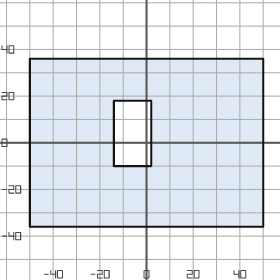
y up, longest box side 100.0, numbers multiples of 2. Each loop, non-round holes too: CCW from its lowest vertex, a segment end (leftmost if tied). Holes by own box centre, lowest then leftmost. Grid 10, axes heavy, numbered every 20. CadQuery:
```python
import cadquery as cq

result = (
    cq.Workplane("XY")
    .moveTo(-50.0, -36.0)
    .lineTo(50.0, -36.0)
    .lineTo(50.0, 36.0)
    .lineTo(-50.0, 36.0)
    .close()
    .moveTo(-14.0, -10.0)
    .lineTo(2.0, -10.0)
    .lineTo(2.0, 18.0)
    .lineTo(-14.0, 18.0)
    .close()
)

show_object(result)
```